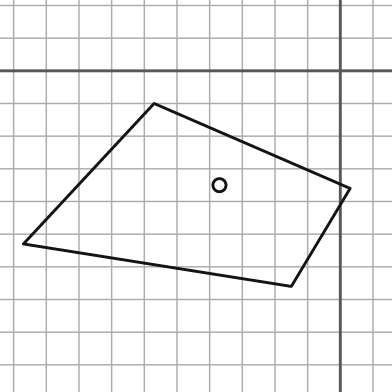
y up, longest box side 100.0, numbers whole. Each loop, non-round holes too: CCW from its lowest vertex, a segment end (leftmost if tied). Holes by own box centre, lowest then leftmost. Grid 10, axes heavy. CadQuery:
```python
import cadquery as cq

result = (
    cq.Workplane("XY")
    .moveTo(-15.0, -66.0)
    .lineTo(3.0, -36.0)
    .lineTo(-57.0, -10.0)
    .lineTo(-97.0, -53.0)
    .close()
    .moveTo(-37.0, -35.0)
    .circle(2.0)
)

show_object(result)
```